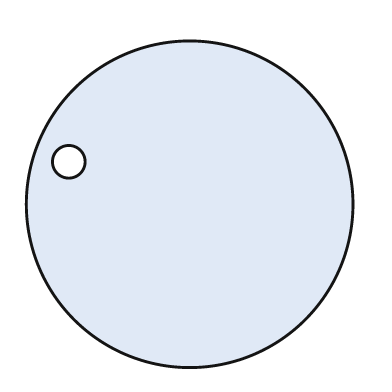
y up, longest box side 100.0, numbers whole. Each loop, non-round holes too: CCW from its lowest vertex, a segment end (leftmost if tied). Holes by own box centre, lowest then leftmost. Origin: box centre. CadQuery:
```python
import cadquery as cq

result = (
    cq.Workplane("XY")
    .moveTo(0.0, 0.0)
    .circle(50.0)
    .moveTo(-37.0, 13.0)
    .circle(5.0)
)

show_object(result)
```